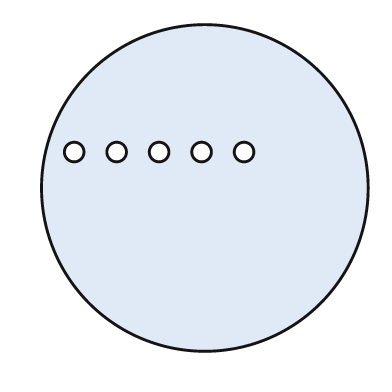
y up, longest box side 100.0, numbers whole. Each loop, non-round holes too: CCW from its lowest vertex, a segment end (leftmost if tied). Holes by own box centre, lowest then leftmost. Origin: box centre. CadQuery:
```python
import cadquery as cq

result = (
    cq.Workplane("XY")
    .moveTo(0.0, 0.0)
    .circle(50.0)
    .moveTo(-40.0, 11.0)
    .circle(3.0)
    .moveTo(-27.0, 11.0)
    .circle(3.0)
    .moveTo(-14.0, 11.0)
    .circle(3.0)
    .moveTo(-1.0, 11.0)
    .circle(3.0)
    .moveTo(12.0, 11.0)
    .circle(3.0)
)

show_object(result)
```